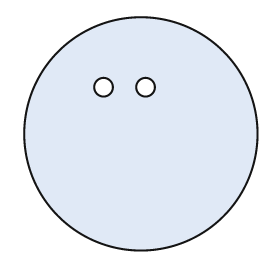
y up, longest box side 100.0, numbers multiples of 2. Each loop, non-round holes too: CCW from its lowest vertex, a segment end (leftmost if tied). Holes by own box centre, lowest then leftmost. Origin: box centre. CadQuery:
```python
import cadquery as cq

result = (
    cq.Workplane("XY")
    .moveTo(0.0, 0.0)
    .circle(50.0)
    .moveTo(-16.0, 20.0)
    .circle(4.0)
    .moveTo(2.0, 20.0)
    .circle(4.0)
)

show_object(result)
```